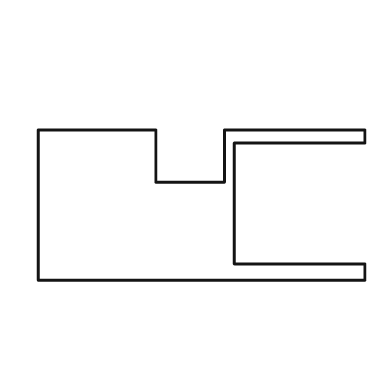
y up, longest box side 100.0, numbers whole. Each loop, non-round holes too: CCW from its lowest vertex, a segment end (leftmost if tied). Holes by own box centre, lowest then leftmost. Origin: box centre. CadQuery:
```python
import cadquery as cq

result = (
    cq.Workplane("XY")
    .moveTo(-50.0, -23.0)
    .lineTo(50.0, -23.0)
    .lineTo(50.0, -18.0)
    .lineTo(10.0, -18.0)
    .lineTo(10.0, 19.0)
    .lineTo(50.0, 19.0)
    .lineTo(50.0, 23.0)
    .lineTo(7.0, 23.0)
    .lineTo(7.0, 7.0)
    .lineTo(-14.0, 7.0)
    .lineTo(-14.0, 23.0)
    .lineTo(-50.0, 23.0)
    .close()
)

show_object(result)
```